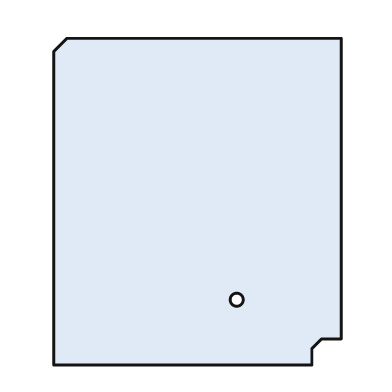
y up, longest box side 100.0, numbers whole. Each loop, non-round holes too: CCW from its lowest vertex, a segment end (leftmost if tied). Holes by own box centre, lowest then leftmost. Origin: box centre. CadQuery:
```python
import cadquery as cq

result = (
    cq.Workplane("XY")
    .moveTo(-44.0, -50.0)
    .lineTo(35.0, -50.0)
    .lineTo(35.0, -45.0)
    .lineTo(38.0, -42.0)
    .lineTo(44.0, -42.0)
    .lineTo(44.0, 50.0)
    .lineTo(-40.0, 50.0)
    .lineTo(-44.0, 46.0)
    .close()
    .moveTo(12.0, -30.0)
    .circle(2.0)
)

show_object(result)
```